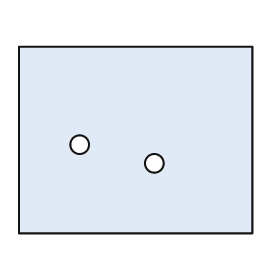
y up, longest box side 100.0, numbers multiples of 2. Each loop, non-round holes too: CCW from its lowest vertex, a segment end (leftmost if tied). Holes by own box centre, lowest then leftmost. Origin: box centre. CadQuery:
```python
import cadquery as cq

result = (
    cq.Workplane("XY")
    .moveTo(-50.0, -40.0)
    .lineTo(50.0, -40.0)
    .lineTo(50.0, 40.0)
    .lineTo(-50.0, 40.0)
    .close()
    .moveTo(8.0, -10.0)
    .circle(4.0)
    .moveTo(-24.0, -2.0)
    .circle(4.0)
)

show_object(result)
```